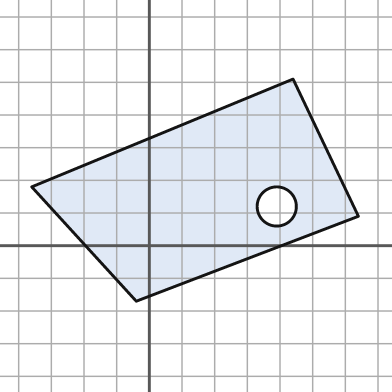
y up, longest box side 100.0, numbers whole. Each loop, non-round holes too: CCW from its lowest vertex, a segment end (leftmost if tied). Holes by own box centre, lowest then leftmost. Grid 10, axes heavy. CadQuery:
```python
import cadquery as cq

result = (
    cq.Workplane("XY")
    .moveTo(-4.0, -17.0)
    .lineTo(64.0, 9.0)
    .lineTo(44.0, 51.0)
    .lineTo(-36.0, 18.0)
    .close()
    .moveTo(39.0, 12.0)
    .circle(6.0)
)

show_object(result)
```